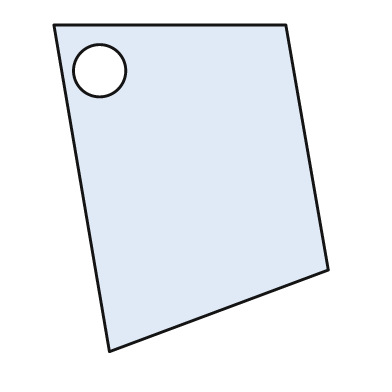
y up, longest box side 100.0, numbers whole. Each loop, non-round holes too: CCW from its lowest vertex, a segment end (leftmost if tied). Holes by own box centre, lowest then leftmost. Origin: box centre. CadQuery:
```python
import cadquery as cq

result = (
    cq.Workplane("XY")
    .moveTo(-25.0, -50.0)
    .lineTo(42.0, -25.0)
    .lineTo(29.0, 50.0)
    .lineTo(-42.0, 50.0)
    .close()
    .moveTo(-28.0, 36.0)
    .circle(8.0)
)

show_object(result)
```